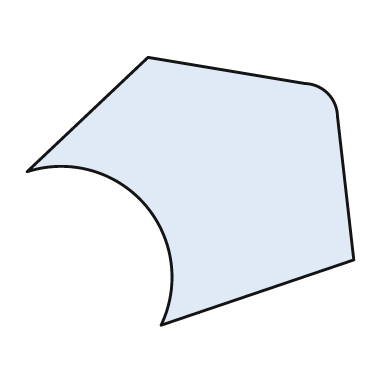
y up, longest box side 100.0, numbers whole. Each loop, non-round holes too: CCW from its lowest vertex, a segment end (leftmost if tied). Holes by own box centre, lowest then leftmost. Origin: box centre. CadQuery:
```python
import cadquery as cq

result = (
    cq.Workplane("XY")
    .moveTo(-9.0, -41.0)
    .lineTo(50.0, -21.0)
    .lineTo(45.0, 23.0)
    .threePointArc((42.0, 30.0), (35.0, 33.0))
    .lineTo(-13.0, 41.0)
    .lineTo(-50.0, 6.0)
    .threePointArc((-14.0, -4.0), (-9.0, -41.0))
    .close()
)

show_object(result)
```